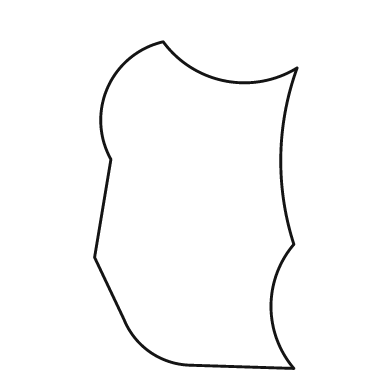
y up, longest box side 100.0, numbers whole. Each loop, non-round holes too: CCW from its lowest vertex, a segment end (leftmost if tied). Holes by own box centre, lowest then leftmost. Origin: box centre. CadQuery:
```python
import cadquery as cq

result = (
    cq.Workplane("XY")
    .moveTo(30.0, -50.0)
    .threePointArc((23.0, -31.0), (30.0, -12.0))
    .threePointArc((26.0, 15.0), (31.0, 42.0))
    .threePointArc((9.0, 38.0), (-10.0, 50.0))
    .threePointArc((-27.0, 36.0), (-26.0, 14.0))
    .lineTo(-31.0, -16.0)
    .lineTo(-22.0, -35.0)
    .threePointArc((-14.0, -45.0), (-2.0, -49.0))
    .close()
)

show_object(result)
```